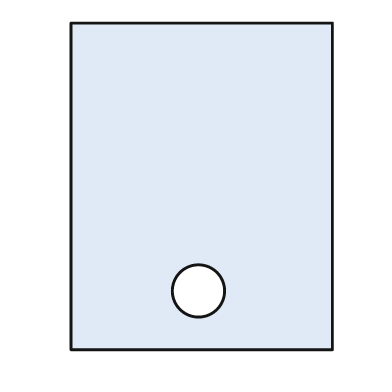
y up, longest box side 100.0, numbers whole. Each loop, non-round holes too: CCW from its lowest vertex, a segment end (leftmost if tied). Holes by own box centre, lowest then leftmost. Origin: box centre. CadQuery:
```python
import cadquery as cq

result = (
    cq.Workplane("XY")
    .moveTo(-40.0, -50.0)
    .lineTo(40.0, -50.0)
    .lineTo(40.0, 50.0)
    .lineTo(-40.0, 50.0)
    .close()
    .moveTo(-1.0, -32.0)
    .circle(8.0)
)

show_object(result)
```